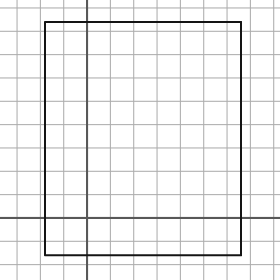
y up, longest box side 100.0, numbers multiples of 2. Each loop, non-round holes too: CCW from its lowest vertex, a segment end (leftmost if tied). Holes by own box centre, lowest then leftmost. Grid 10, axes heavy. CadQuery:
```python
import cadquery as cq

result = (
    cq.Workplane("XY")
    .moveTo(-18.0, -16.0)
    .lineTo(66.0, -16.0)
    .lineTo(66.0, 84.0)
    .lineTo(-18.0, 84.0)
    .close()
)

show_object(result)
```